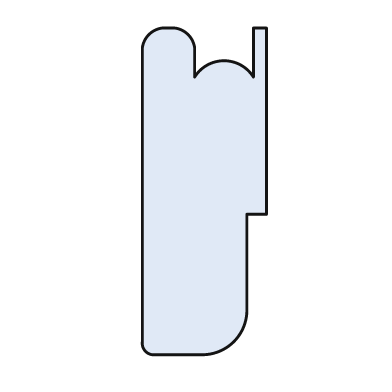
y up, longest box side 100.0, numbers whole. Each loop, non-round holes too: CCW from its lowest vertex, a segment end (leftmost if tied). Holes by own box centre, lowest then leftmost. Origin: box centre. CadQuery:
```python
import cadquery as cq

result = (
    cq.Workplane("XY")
    .moveTo(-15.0, -50.0)
    .lineTo(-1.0, -50.0)
    .threePointArc((9.0, -46.0), (13.0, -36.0))
    .lineTo(13.0, -7.0)
    .lineTo(19.0, -7.0)
    .lineTo(19.0, 50.0)
    .lineTo(15.0, 50.0)
    .lineTo(15.0, 35.0)
    .threePointArc((6.0, 40.0), (-3.0, 35.0))
    .lineTo(-3.0, 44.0)
    .threePointArc((-5.0, 48.0), (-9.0, 50.0))
    .lineTo(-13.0, 50.0)
    .threePointArc((-17.0, 48.0), (-19.0, 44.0))
    .lineTo(-19.0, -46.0)
    .threePointArc((-18.0, -49.0), (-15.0, -50.0))
    .close()
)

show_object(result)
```